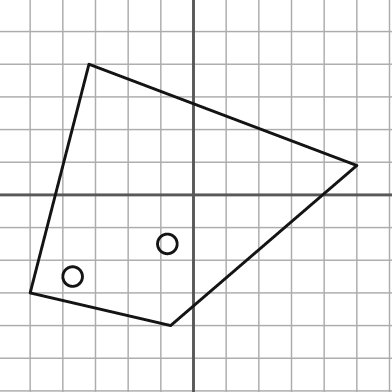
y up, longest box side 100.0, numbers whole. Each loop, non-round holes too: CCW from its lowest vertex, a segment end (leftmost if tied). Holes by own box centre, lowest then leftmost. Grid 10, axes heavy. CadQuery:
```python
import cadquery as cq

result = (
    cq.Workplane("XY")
    .moveTo(-7.0, -40.0)
    .lineTo(50.0, 9.0)
    .lineTo(-32.0, 40.0)
    .lineTo(-50.0, -30.0)
    .close()
    .moveTo(-37.0, -25.0)
    .circle(3.0)
    .moveTo(-8.0, -15.0)
    .circle(3.0)
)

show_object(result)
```